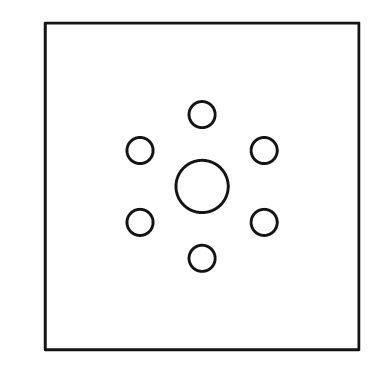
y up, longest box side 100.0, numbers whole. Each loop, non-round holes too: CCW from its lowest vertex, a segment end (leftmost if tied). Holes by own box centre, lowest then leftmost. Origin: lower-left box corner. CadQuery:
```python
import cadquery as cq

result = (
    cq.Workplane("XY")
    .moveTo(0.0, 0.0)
    .lineTo(96.0, 0.0)
    .lineTo(96.0, 100.0)
    .lineTo(0.0, 100.0)
    .close()
    .moveTo(48.0, 28.0)
    .circle(4.0)
    .moveTo(29.0, 39.0)
    .circle(4.0)
    .moveTo(67.0, 39.0)
    .circle(4.0)
    .moveTo(48.0, 50.0)
    .circle(8.0)
    .moveTo(29.0, 61.0)
    .circle(4.0)
    .moveTo(67.0, 61.0)
    .circle(4.0)
    .moveTo(48.0, 72.0)
    .circle(4.0)
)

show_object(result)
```